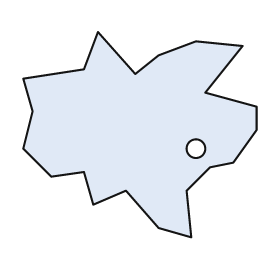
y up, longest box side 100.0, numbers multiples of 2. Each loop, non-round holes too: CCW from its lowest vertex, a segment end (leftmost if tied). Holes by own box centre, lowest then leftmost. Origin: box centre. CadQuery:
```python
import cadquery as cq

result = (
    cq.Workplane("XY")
    .moveTo(22.0, -44.0)
    .lineTo(20.0, -24.0)
    .lineTo(30.0, -14.0)
    .lineTo(40.0, -12.0)
    .lineTo(50.0, 2.0)
    .lineTo(50.0, 12.0)
    .lineTo(28.0, 18.0)
    .lineTo(44.0, 38.0)
    .lineTo(24.0, 40.0)
    .lineTo(8.0, 34.0)
    .lineTo(-2.0, 26.0)
    .lineTo(-18.0, 44.0)
    .lineTo(-24.0, 28.0)
    .lineTo(-50.0, 24.0)
    .lineTo(-46.0, 10.0)
    .lineTo(-50.0, -6.0)
    .lineTo(-38.0, -18.0)
    .lineTo(-24.0, -16.0)
    .lineTo(-20.0, -30.0)
    .lineTo(-6.0, -24.0)
    .lineTo(8.0, -40.0)
    .close()
    .moveTo(24.0, -6.0)
    .circle(4.0)
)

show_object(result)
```